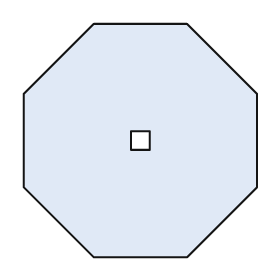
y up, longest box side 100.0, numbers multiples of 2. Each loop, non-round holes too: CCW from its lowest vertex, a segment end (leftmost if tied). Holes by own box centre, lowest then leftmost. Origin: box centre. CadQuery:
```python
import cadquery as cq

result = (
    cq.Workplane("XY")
    .moveTo(-20.0, -50.0)
    .lineTo(20.0, -50.0)
    .lineTo(50.0, -20.0)
    .lineTo(50.0, 20.0)
    .lineTo(20.0, 50.0)
    .lineTo(-20.0, 50.0)
    .lineTo(-50.0, 20.0)
    .lineTo(-50.0, -20.0)
    .close()
    .moveTo(-4.0, -4.0)
    .lineTo(4.0, -4.0)
    .lineTo(4.0, 4.0)
    .lineTo(-4.0, 4.0)
    .close()
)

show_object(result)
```